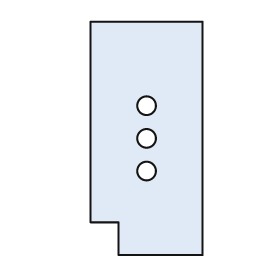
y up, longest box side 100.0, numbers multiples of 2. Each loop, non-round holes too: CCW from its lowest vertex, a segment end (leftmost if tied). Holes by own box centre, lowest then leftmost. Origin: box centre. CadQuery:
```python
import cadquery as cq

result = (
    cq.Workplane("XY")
    .moveTo(-12.0, -50.0)
    .lineTo(24.0, -50.0)
    .lineTo(24.0, 50.0)
    .lineTo(-24.0, 50.0)
    .lineTo(-24.0, -36.0)
    .lineTo(-12.0, -36.0)
    .close()
    .moveTo(0.0, -14.0)
    .circle(4.0)
    .moveTo(0.0, 0.0)
    .circle(4.0)
    .moveTo(0.0, 14.0)
    .circle(4.0)
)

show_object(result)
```